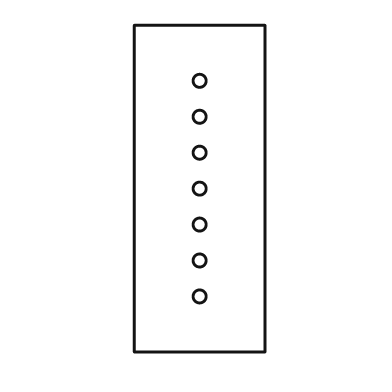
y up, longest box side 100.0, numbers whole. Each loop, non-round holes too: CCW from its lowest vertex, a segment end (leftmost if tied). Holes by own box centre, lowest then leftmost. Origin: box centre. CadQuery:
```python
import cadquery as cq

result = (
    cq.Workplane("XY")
    .moveTo(-20.0, -50.0)
    .lineTo(20.0, -50.0)
    .lineTo(20.0, 50.0)
    .lineTo(-20.0, 50.0)
    .close()
    .moveTo(0.0, -33.0)
    .circle(2.0)
    .moveTo(0.0, -22.0)
    .circle(2.0)
    .moveTo(0.0, -11.0)
    .circle(2.0)
    .moveTo(0.0, 0.0)
    .circle(2.0)
    .moveTo(0.0, 11.0)
    .circle(2.0)
    .moveTo(0.0, 22.0)
    .circle(2.0)
    .moveTo(0.0, 33.0)
    .circle(2.0)
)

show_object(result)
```